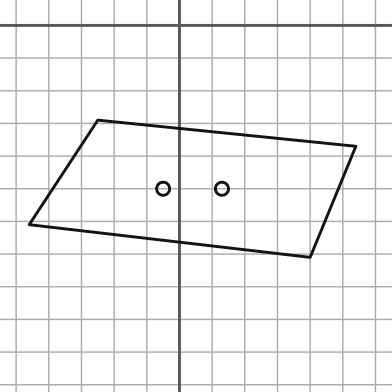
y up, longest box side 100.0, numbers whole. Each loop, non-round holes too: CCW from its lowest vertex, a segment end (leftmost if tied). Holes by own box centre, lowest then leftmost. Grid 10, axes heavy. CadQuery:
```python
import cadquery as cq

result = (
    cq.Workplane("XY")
    .moveTo(40.0, -71.0)
    .lineTo(54.0, -37.0)
    .lineTo(-25.0, -29.0)
    .lineTo(-46.0, -61.0)
    .close()
    .moveTo(-5.0, -50.0)
    .circle(2.0)
    .moveTo(13.0, -50.0)
    .circle(2.0)
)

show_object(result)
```